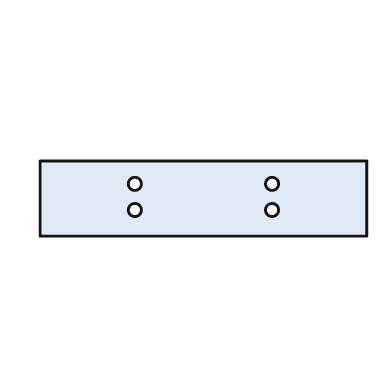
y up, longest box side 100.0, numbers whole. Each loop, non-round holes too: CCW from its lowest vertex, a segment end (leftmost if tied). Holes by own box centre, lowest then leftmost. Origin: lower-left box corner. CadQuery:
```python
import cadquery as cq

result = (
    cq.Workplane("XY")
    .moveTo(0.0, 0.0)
    .lineTo(100.0, 0.0)
    .lineTo(100.0, 23.0)
    .lineTo(0.0, 23.0)
    .close()
    .moveTo(29.0, 8.0)
    .circle(2.0)
    .moveTo(71.0, 8.0)
    .circle(2.0)
    .moveTo(29.0, 16.0)
    .circle(2.0)
    .moveTo(71.0, 16.0)
    .circle(2.0)
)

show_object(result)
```